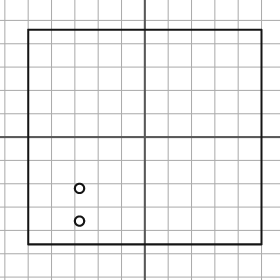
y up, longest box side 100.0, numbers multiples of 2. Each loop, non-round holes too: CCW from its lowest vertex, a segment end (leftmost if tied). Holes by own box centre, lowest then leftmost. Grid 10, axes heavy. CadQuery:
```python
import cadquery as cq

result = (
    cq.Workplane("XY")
    .moveTo(-50.0, -46.0)
    .lineTo(50.0, -46.0)
    .lineTo(50.0, 46.0)
    .lineTo(-50.0, 46.0)
    .close()
    .moveTo(-28.0, -36.0)
    .circle(2.0)
    .moveTo(-28.0, -22.0)
    .circle(2.0)
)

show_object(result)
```